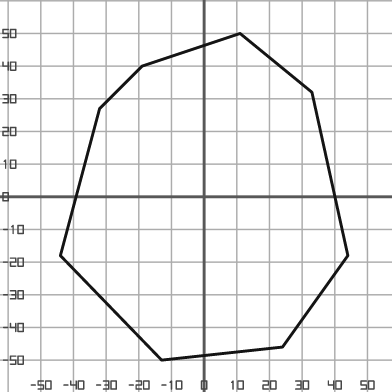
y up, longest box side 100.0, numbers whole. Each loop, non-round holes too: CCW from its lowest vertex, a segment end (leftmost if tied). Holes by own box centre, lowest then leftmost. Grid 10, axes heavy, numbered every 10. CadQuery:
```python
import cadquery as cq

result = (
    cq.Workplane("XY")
    .moveTo(-13.0, -50.0)
    .lineTo(24.0, -46.0)
    .lineTo(44.0, -18.0)
    .lineTo(33.0, 32.0)
    .lineTo(11.0, 50.0)
    .lineTo(-19.0, 40.0)
    .lineTo(-32.0, 27.0)
    .lineTo(-44.0, -18.0)
    .close()
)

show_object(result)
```